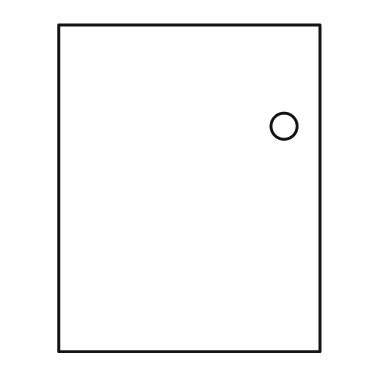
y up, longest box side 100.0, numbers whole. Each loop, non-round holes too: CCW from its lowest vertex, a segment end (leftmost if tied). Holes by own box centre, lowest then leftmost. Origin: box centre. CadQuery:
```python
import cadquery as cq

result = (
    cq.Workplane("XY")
    .moveTo(-40.0, -50.0)
    .lineTo(40.0, -50.0)
    .lineTo(40.0, 50.0)
    .lineTo(-40.0, 50.0)
    .close()
    .moveTo(29.0, 19.0)
    .circle(4.0)
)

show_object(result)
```